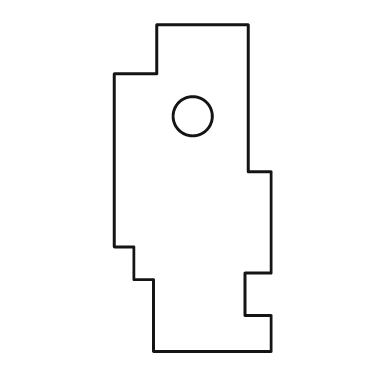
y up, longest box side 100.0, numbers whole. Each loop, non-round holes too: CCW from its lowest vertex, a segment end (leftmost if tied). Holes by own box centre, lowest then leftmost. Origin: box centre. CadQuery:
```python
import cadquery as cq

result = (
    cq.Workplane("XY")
    .moveTo(-12.0, -50.0)
    .lineTo(24.0, -50.0)
    .lineTo(24.0, -39.0)
    .lineTo(16.0, -39.0)
    .lineTo(16.0, -26.0)
    .lineTo(24.0, -26.0)
    .lineTo(24.0, 5.0)
    .lineTo(17.0, 5.0)
    .lineTo(17.0, 50.0)
    .lineTo(-11.0, 50.0)
    .lineTo(-11.0, 35.0)
    .lineTo(-24.0, 35.0)
    .lineTo(-24.0, -18.0)
    .lineTo(-18.0, -18.0)
    .lineTo(-18.0, -28.0)
    .lineTo(-12.0, -28.0)
    .close()
    .moveTo(0.0, 22.0)
    .circle(6.0)
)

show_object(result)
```